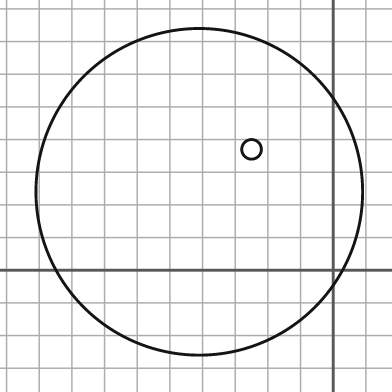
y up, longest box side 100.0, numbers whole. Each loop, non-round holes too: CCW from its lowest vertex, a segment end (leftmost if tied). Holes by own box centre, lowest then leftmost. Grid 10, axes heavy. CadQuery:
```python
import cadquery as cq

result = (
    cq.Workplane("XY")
    .moveTo(-41.0, 24.0)
    .circle(50.0)
    .moveTo(-25.0, 37.0)
    .circle(3.0)
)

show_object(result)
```